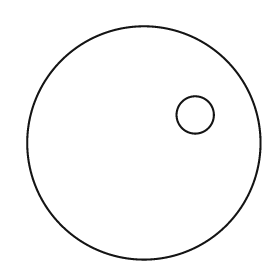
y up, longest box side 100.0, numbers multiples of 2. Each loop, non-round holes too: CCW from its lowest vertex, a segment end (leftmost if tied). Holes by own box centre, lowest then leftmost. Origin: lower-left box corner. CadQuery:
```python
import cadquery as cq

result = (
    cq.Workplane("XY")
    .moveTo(50.0, 50.0)
    .circle(50.0)
    .moveTo(72.0, 62.0)
    .circle(8.0)
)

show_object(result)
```